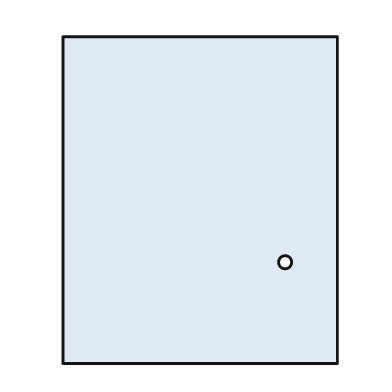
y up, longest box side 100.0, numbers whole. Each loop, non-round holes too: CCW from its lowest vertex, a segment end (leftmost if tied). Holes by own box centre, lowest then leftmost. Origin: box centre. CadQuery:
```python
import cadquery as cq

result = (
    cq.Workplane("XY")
    .moveTo(-42.0, -50.0)
    .lineTo(42.0, -50.0)
    .lineTo(42.0, 50.0)
    .lineTo(-42.0, 50.0)
    .close()
    .moveTo(26.0, -19.0)
    .circle(2.0)
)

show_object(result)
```